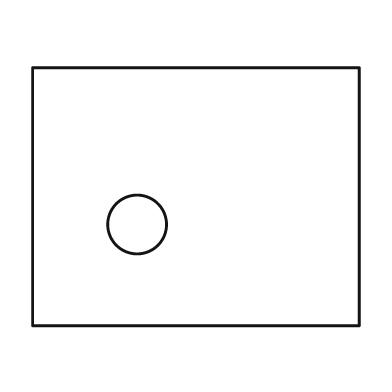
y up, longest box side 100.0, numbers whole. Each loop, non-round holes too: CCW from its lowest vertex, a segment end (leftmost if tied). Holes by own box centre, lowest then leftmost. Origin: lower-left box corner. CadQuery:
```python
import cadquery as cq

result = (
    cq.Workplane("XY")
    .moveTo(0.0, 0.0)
    .lineTo(100.0, 0.0)
    .lineTo(100.0, 79.0)
    .lineTo(0.0, 79.0)
    .close()
    .moveTo(32.0, 31.0)
    .circle(9.0)
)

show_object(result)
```